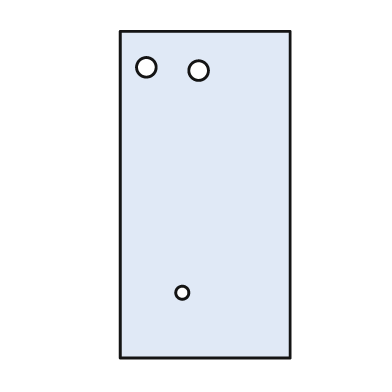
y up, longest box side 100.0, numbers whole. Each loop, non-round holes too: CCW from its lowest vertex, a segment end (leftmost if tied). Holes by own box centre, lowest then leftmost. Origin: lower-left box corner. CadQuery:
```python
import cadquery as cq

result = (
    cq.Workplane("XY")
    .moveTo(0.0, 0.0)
    .lineTo(52.0, 0.0)
    .lineTo(52.0, 100.0)
    .lineTo(0.0, 100.0)
    .close()
    .moveTo(19.0, 20.0)
    .circle(2.0)
    .moveTo(24.0, 88.0)
    .circle(3.0)
    .moveTo(8.0, 89.0)
    .circle(3.0)
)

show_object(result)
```